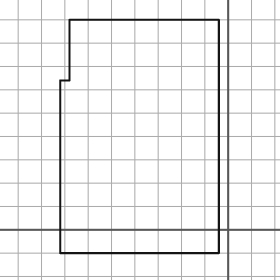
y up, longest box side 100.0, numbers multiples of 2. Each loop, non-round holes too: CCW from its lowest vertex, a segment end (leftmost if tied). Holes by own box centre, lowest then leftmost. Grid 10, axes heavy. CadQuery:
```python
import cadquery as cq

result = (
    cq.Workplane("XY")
    .moveTo(-72.0, -10.0)
    .lineTo(-4.0, -10.0)
    .lineTo(-4.0, 90.0)
    .lineTo(-68.0, 90.0)
    .lineTo(-68.0, 64.0)
    .lineTo(-72.0, 64.0)
    .close()
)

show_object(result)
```